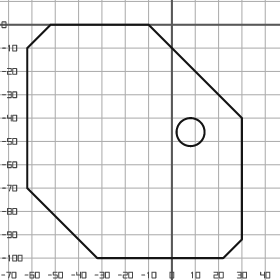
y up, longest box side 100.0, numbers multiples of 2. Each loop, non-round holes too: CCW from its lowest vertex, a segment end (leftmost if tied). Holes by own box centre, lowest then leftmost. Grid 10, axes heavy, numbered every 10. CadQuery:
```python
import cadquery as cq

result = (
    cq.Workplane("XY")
    .moveTo(-32.0, -100.0)
    .lineTo(22.0, -100.0)
    .lineTo(30.0, -92.0)
    .lineTo(30.0, -40.0)
    .lineTo(-10.0, 0.0)
    .lineTo(-52.0, 0.0)
    .lineTo(-62.0, -10.0)
    .lineTo(-62.0, -70.0)
    .close()
    .moveTo(8.0, -46.0)
    .circle(6.0)
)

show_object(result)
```